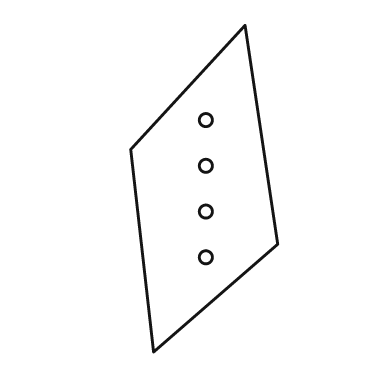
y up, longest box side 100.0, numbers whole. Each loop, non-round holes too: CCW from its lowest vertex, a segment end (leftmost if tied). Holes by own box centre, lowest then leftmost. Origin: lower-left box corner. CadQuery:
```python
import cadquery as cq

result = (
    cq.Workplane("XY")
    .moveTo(7.0, 0.0)
    .lineTo(45.0, 33.0)
    .lineTo(35.0, 100.0)
    .lineTo(0.0, 62.0)
    .close()
    .moveTo(23.0, 29.0)
    .circle(2.0)
    .moveTo(23.0, 43.0)
    .circle(2.0)
    .moveTo(23.0, 57.0)
    .circle(2.0)
    .moveTo(23.0, 71.0)
    .circle(2.0)
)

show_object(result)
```